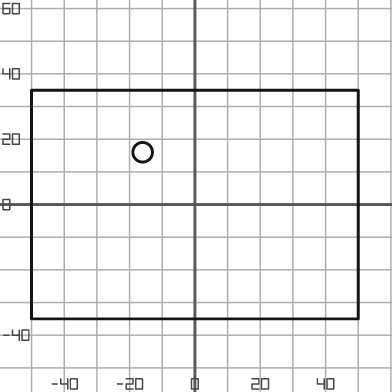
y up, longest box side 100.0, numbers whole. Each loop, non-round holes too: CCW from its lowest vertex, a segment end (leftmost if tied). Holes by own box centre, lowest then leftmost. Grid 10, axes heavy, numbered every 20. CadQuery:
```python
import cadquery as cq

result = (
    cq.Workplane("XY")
    .moveTo(-50.0, -35.0)
    .lineTo(50.0, -35.0)
    .lineTo(50.0, 35.0)
    .lineTo(-50.0, 35.0)
    .close()
    .moveTo(-16.0, 16.0)
    .circle(3.0)
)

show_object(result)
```